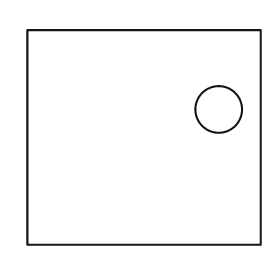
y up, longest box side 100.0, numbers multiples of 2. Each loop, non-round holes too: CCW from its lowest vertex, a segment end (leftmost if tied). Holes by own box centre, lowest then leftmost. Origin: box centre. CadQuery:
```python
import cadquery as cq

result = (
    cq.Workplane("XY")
    .moveTo(-50.0, -46.0)
    .lineTo(50.0, -46.0)
    .lineTo(50.0, 46.0)
    .lineTo(-50.0, 46.0)
    .close()
    .moveTo(32.0, 12.0)
    .circle(10.0)
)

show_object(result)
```